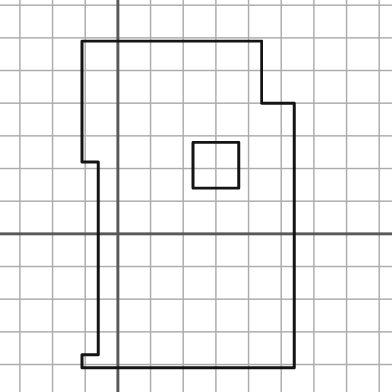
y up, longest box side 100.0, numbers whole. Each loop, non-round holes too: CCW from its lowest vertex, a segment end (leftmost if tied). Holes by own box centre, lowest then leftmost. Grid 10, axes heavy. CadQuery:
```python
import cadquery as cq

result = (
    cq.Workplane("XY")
    .moveTo(-11.0, -41.0)
    .lineTo(54.0, -41.0)
    .lineTo(54.0, 40.0)
    .lineTo(44.0, 40.0)
    .lineTo(44.0, 59.0)
    .lineTo(-11.0, 59.0)
    .lineTo(-11.0, 22.0)
    .lineTo(-6.0, 22.0)
    .lineTo(-6.0, -37.0)
    .lineTo(-11.0, -37.0)
    .close()
    .moveTo(23.0, 14.0)
    .lineTo(37.0, 14.0)
    .lineTo(37.0, 28.0)
    .lineTo(23.0, 28.0)
    .close()
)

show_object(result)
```